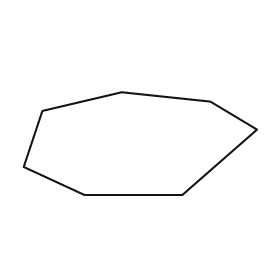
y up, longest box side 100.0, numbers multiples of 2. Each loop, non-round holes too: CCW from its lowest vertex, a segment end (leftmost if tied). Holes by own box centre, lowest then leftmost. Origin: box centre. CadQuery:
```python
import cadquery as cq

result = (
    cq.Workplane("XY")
    .moveTo(-24.0, -22.0)
    .lineTo(18.0, -22.0)
    .lineTo(50.0, 6.0)
    .lineTo(30.0, 18.0)
    .lineTo(-8.0, 22.0)
    .lineTo(-42.0, 14.0)
    .lineTo(-50.0, -10.0)
    .close()
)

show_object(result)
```